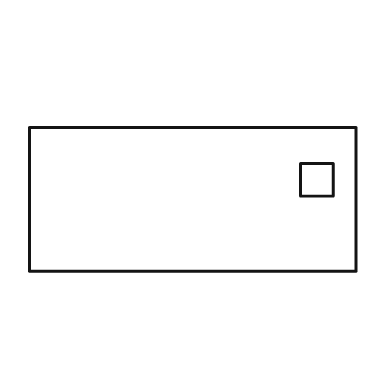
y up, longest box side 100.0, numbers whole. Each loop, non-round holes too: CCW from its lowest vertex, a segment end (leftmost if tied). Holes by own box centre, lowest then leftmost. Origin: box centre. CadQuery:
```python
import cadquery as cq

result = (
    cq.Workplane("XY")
    .moveTo(-50.0, -22.0)
    .lineTo(50.0, -22.0)
    .lineTo(50.0, 22.0)
    .lineTo(-50.0, 22.0)
    .close()
    .moveTo(33.0, 1.0)
    .lineTo(43.0, 1.0)
    .lineTo(43.0, 11.0)
    .lineTo(33.0, 11.0)
    .close()
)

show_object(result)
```